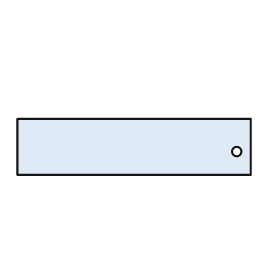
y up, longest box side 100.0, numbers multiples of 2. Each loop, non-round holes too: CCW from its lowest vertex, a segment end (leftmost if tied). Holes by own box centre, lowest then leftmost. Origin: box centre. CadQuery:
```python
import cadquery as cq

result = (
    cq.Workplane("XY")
    .moveTo(-50.0, -12.0)
    .lineTo(50.0, -12.0)
    .lineTo(50.0, 12.0)
    .lineTo(-50.0, 12.0)
    .close()
    .moveTo(44.0, -2.0)
    .circle(2.0)
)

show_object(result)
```